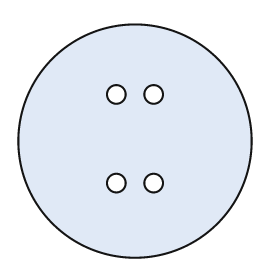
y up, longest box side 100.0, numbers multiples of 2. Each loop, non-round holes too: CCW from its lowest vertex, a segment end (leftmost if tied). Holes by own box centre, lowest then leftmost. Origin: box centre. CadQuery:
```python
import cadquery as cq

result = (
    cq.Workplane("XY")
    .moveTo(0.0, 0.0)
    .circle(50.0)
    .moveTo(-8.0, -18.0)
    .circle(4.0)
    .moveTo(8.0, -18.0)
    .circle(4.0)
    .moveTo(-8.0, 20.0)
    .circle(4.0)
    .moveTo(8.0, 20.0)
    .circle(4.0)
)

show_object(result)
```